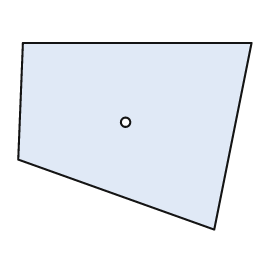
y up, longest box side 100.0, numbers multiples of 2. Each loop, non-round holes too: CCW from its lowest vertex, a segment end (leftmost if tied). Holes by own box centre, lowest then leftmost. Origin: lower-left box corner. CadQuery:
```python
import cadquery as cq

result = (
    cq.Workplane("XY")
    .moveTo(84.0, 0.0)
    .lineTo(100.0, 80.0)
    .lineTo(2.0, 80.0)
    .lineTo(0.0, 30.0)
    .close()
    .moveTo(46.0, 46.0)
    .circle(2.0)
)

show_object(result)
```